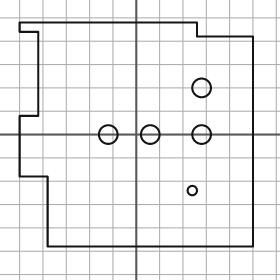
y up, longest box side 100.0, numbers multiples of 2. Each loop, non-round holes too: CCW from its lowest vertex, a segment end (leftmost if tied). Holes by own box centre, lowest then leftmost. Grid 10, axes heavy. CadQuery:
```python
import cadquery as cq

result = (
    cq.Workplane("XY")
    .moveTo(-38.0, -48.0)
    .lineTo(50.0, -48.0)
    .lineTo(50.0, 42.0)
    .lineTo(26.0, 42.0)
    .lineTo(26.0, 48.0)
    .lineTo(-50.0, 48.0)
    .lineTo(-50.0, 44.0)
    .lineTo(-42.0, 44.0)
    .lineTo(-42.0, 8.0)
    .lineTo(-50.0, 8.0)
    .lineTo(-50.0, -18.0)
    .lineTo(-38.0, -18.0)
    .close()
    .moveTo(24.0, -24.0)
    .circle(2.0)
    .moveTo(-12.0, 0.0)
    .circle(4.0)
    .moveTo(6.0, 0.0)
    .circle(4.0)
    .moveTo(28.0, 0.0)
    .circle(4.0)
    .moveTo(28.0, 20.0)
    .circle(4.0)
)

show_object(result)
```